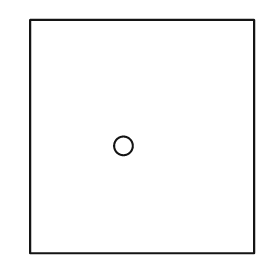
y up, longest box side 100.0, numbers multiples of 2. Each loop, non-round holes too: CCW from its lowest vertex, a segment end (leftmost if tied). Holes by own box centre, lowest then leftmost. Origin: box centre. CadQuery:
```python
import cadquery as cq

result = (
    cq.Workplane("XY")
    .moveTo(-48.0, -50.0)
    .lineTo(48.0, -50.0)
    .lineTo(48.0, 50.0)
    .lineTo(-48.0, 50.0)
    .close()
    .moveTo(-8.0, -4.0)
    .circle(4.0)
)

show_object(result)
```